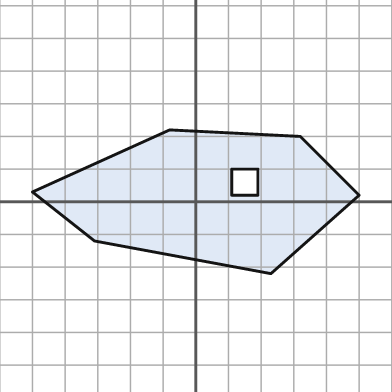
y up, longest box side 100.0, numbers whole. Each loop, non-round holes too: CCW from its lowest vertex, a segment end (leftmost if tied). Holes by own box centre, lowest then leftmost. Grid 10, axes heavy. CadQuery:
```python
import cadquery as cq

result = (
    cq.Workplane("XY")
    .moveTo(23.0, -22.0)
    .lineTo(50.0, 2.0)
    .lineTo(32.0, 20.0)
    .lineTo(-8.0, 22.0)
    .lineTo(-50.0, 3.0)
    .lineTo(-31.0, -12.0)
    .close()
    .moveTo(11.0, 2.0)
    .lineTo(19.0, 2.0)
    .lineTo(19.0, 10.0)
    .lineTo(11.0, 10.0)
    .close()
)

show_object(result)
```